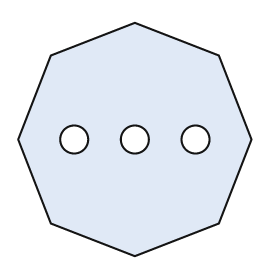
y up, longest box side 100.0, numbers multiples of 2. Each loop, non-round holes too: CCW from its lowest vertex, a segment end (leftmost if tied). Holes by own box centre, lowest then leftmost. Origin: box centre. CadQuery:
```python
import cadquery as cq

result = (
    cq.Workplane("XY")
    .moveTo(0.0, -50.0)
    .lineTo(36.0, -36.0)
    .lineTo(50.0, 0.0)
    .lineTo(36.0, 36.0)
    .lineTo(0.0, 50.0)
    .lineTo(-36.0, 36.0)
    .lineTo(-50.0, 0.0)
    .lineTo(-36.0, -36.0)
    .close()
    .moveTo(-26.0, 0.0)
    .circle(6.0)
    .moveTo(0.0, 0.0)
    .circle(6.0)
    .moveTo(26.0, 0.0)
    .circle(6.0)
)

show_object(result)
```